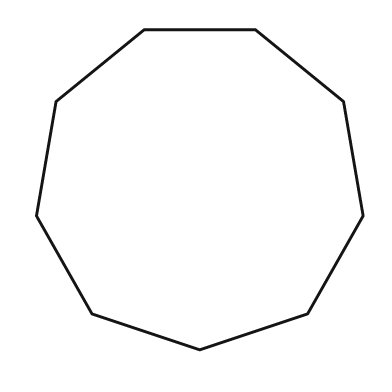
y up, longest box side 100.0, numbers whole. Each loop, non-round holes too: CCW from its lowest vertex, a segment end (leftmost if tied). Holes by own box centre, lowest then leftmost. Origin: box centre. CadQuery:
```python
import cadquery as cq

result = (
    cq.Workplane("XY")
    .moveTo(0.0, -49.0)
    .lineTo(33.0, -38.0)
    .lineTo(50.0, -8.0)
    .lineTo(44.0, 27.0)
    .lineTo(17.0, 49.0)
    .lineTo(-17.0, 49.0)
    .lineTo(-44.0, 27.0)
    .lineTo(-50.0, -8.0)
    .lineTo(-33.0, -38.0)
    .close()
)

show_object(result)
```